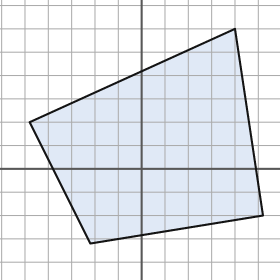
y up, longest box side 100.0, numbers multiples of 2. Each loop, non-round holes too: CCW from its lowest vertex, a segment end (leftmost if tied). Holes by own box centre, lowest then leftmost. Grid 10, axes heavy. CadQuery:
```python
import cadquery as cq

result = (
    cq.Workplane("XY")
    .moveTo(-22.0, -32.0)
    .lineTo(52.0, -20.0)
    .lineTo(40.0, 60.0)
    .lineTo(-48.0, 20.0)
    .close()
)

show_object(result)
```